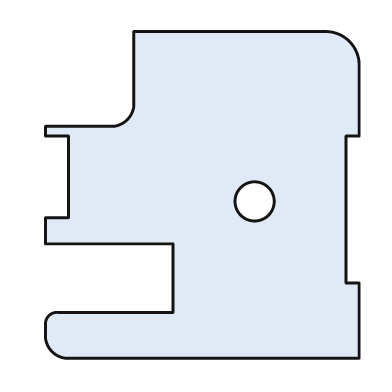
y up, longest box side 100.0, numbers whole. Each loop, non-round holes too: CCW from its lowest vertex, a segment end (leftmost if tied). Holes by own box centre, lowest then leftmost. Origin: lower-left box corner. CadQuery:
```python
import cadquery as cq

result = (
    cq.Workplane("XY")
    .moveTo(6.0, 0.0)
    .lineTo(96.0, 0.0)
    .lineTo(96.0, 23.0)
    .lineTo(92.0, 23.0)
    .lineTo(92.0, 68.0)
    .lineTo(96.0, 68.0)
    .lineTo(96.0, 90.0)
    .threePointArc((93.0, 97.0), (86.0, 100.0))
    .lineTo(27.0, 100.0)
    .lineTo(27.0, 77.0)
    .threePointArc((25.0, 73.0), (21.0, 71.0))
    .lineTo(0.0, 71.0)
    .lineTo(0.0, 68.0)
    .lineTo(7.0, 68.0)
    .lineTo(7.0, 43.0)
    .lineTo(0.0, 43.0)
    .lineTo(0.0, 35.0)
    .lineTo(39.0, 35.0)
    .lineTo(39.0, 14.0)
    .lineTo(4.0, 14.0)
    .threePointArc((1.0, 13.0), (0.0, 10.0))
    .lineTo(0.0, 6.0)
    .threePointArc((2.0, 2.0), (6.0, 0.0))
    .close()
    .moveTo(64.0, 48.0)
    .circle(6.0)
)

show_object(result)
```